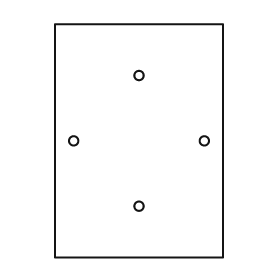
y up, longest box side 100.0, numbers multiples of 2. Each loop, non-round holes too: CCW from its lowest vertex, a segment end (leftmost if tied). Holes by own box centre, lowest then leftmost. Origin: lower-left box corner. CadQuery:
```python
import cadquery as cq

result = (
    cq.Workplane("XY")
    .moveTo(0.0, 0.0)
    .lineTo(72.0, 0.0)
    .lineTo(72.0, 100.0)
    .lineTo(0.0, 100.0)
    .close()
    .moveTo(36.0, 22.0)
    .circle(2.0)
    .moveTo(8.0, 50.0)
    .circle(2.0)
    .moveTo(64.0, 50.0)
    .circle(2.0)
    .moveTo(36.0, 78.0)
    .circle(2.0)
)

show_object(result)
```